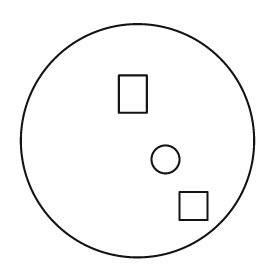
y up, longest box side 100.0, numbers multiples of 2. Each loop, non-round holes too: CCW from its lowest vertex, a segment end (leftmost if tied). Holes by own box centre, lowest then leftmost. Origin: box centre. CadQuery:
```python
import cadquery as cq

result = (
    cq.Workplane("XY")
    .moveTo(0.0, 0.0)
    .circle(50.0)
    .moveTo(18.0, -34.0)
    .lineTo(30.0, -34.0)
    .lineTo(30.0, -22.0)
    .lineTo(18.0, -22.0)
    .close()
    .moveTo(12.0, -8.0)
    .circle(6.0)
    .moveTo(-8.0, 12.0)
    .lineTo(4.0, 12.0)
    .lineTo(4.0, 28.0)
    .lineTo(-8.0, 28.0)
    .close()
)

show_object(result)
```